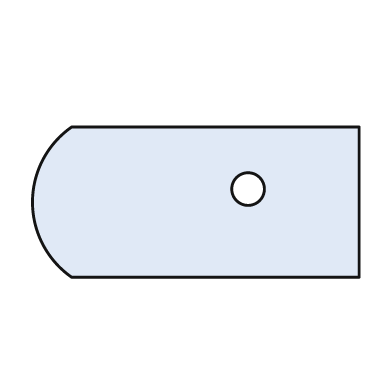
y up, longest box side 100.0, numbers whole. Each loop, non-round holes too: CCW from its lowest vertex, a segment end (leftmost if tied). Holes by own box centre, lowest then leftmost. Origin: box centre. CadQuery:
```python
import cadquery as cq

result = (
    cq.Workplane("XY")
    .moveTo(-38.0, -23.0)
    .lineTo(50.0, -23.0)
    .lineTo(50.0, 23.0)
    .lineTo(-38.0, 23.0)
    .threePointArc((-50.0, 0.0), (-38.0, -23.0))
    .close()
    .moveTo(16.0, 4.0)
    .circle(5.0)
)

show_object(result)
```